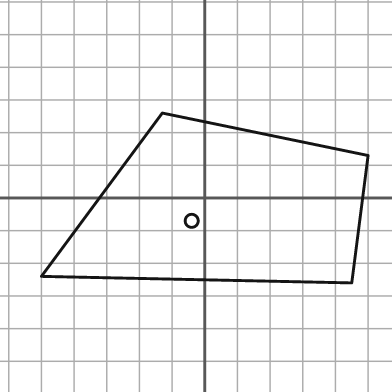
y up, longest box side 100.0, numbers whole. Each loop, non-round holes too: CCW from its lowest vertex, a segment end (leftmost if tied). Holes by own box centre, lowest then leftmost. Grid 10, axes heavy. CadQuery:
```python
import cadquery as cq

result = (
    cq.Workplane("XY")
    .moveTo(45.0, -26.0)
    .lineTo(50.0, 13.0)
    .lineTo(-13.0, 26.0)
    .lineTo(-50.0, -24.0)
    .close()
    .moveTo(-4.0, -7.0)
    .circle(2.0)
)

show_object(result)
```